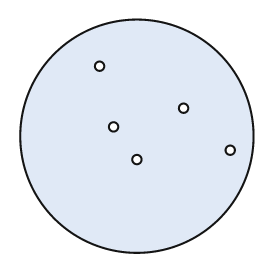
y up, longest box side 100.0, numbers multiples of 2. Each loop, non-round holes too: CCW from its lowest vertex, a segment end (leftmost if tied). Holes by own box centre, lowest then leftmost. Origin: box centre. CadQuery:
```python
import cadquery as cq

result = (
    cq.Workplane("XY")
    .moveTo(0.0, 0.0)
    .circle(50.0)
    .moveTo(0.0, -10.0)
    .circle(2.0)
    .moveTo(40.0, -6.0)
    .circle(2.0)
    .moveTo(-10.0, 4.0)
    .circle(2.0)
    .moveTo(20.0, 12.0)
    .circle(2.0)
    .moveTo(-16.0, 30.0)
    .circle(2.0)
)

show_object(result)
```